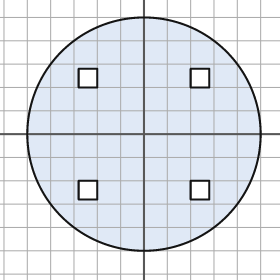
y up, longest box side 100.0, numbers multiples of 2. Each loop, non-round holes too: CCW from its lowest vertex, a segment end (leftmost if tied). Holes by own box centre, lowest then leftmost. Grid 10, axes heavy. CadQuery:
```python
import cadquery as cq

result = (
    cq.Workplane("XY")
    .moveTo(0.0, 0.0)
    .circle(50.0)
    .moveTo(-28.0, -28.0)
    .lineTo(-20.0, -28.0)
    .lineTo(-20.0, -20.0)
    .lineTo(-28.0, -20.0)
    .close()
    .moveTo(20.0, -28.0)
    .lineTo(28.0, -28.0)
    .lineTo(28.0, -20.0)
    .lineTo(20.0, -20.0)
    .close()
    .moveTo(-28.0, 20.0)
    .lineTo(-20.0, 20.0)
    .lineTo(-20.0, 28.0)
    .lineTo(-28.0, 28.0)
    .close()
    .moveTo(20.0, 20.0)
    .lineTo(28.0, 20.0)
    .lineTo(28.0, 28.0)
    .lineTo(20.0, 28.0)
    .close()
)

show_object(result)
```